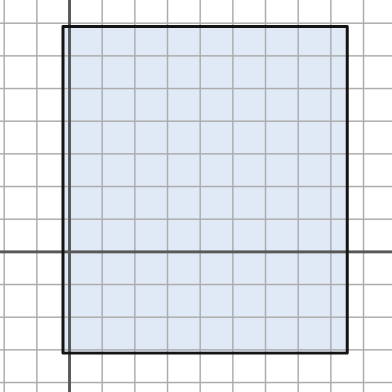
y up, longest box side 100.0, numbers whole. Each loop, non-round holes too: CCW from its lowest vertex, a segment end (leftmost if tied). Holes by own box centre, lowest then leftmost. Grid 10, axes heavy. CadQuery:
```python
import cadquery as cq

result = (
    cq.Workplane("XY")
    .moveTo(-2.0, -31.0)
    .lineTo(85.0, -31.0)
    .lineTo(85.0, 69.0)
    .lineTo(-2.0, 69.0)
    .close()
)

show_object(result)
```